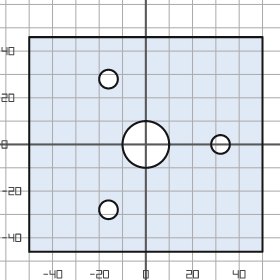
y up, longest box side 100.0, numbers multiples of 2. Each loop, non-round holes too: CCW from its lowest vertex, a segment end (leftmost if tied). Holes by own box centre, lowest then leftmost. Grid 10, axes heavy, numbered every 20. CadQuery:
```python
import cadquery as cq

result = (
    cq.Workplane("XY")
    .moveTo(-50.0, -46.0)
    .lineTo(50.0, -46.0)
    .lineTo(50.0, 46.0)
    .lineTo(-50.0, 46.0)
    .close()
    .moveTo(-16.0, -28.0)
    .circle(4.0)
    .moveTo(0.0, 0.0)
    .circle(10.0)
    .moveTo(32.0, 0.0)
    .circle(4.0)
    .moveTo(-16.0, 28.0)
    .circle(4.0)
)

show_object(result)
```